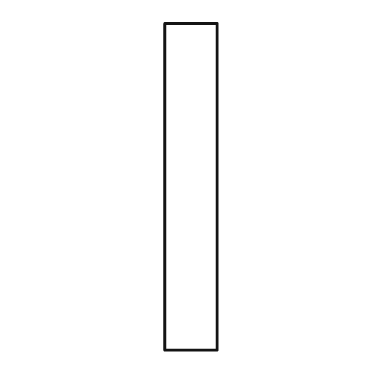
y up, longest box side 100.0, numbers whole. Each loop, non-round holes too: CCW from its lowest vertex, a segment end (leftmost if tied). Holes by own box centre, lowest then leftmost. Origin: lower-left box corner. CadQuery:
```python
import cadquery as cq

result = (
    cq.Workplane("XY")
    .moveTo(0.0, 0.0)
    .lineTo(16.0, 0.0)
    .lineTo(16.0, 100.0)
    .lineTo(0.0, 100.0)
    .close()
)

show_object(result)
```